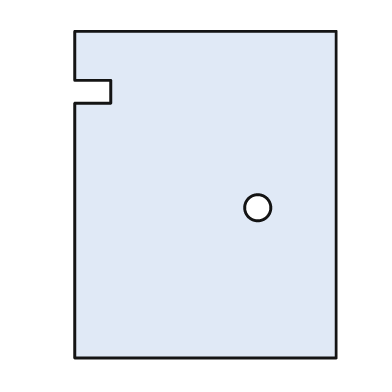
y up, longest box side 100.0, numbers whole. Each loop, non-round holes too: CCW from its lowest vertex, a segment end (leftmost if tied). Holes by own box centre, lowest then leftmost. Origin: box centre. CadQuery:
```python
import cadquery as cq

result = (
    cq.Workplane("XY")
    .moveTo(-40.0, -50.0)
    .lineTo(40.0, -50.0)
    .lineTo(40.0, 50.0)
    .lineTo(-40.0, 50.0)
    .lineTo(-40.0, 35.0)
    .lineTo(-29.0, 35.0)
    .lineTo(-29.0, 28.0)
    .lineTo(-40.0, 28.0)
    .close()
    .moveTo(16.0, -4.0)
    .circle(4.0)
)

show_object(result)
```